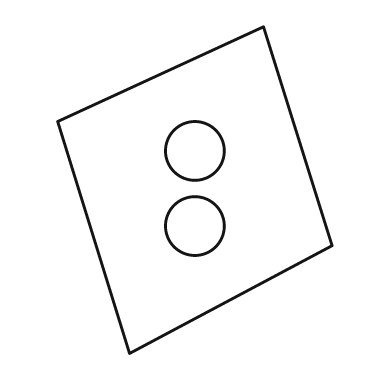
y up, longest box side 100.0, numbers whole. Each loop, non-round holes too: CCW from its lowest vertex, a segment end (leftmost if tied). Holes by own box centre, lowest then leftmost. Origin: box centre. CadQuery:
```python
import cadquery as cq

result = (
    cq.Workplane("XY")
    .moveTo(-20.0, -50.0)
    .lineTo(42.0, -17.0)
    .lineTo(21.0, 50.0)
    .lineTo(-42.0, 21.0)
    .close()
    .moveTo(0.0, -11.0)
    .circle(9.0)
    .moveTo(0.0, 12.0)
    .circle(9.0)
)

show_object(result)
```